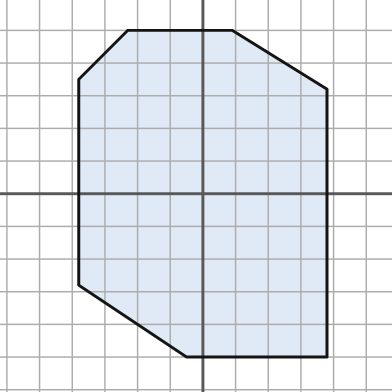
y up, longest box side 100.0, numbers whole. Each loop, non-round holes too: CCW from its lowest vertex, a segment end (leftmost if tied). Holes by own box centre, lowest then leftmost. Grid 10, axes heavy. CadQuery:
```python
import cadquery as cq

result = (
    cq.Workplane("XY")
    .moveTo(-5.0, -50.0)
    .lineTo(38.0, -50.0)
    .lineTo(38.0, 32.0)
    .lineTo(9.0, 50.0)
    .lineTo(-23.0, 50.0)
    .lineTo(-38.0, 35.0)
    .lineTo(-38.0, -28.0)
    .close()
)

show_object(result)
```